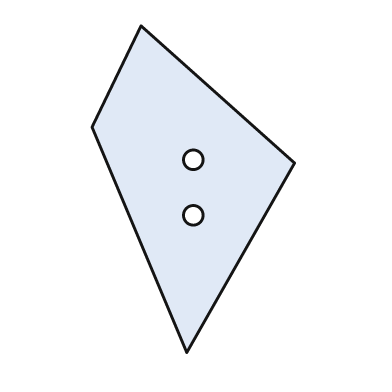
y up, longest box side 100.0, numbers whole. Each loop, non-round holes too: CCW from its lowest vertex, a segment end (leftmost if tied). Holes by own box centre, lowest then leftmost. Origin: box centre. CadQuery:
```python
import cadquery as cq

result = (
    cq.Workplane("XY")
    .moveTo(-2.0, -50.0)
    .lineTo(31.0, 8.0)
    .lineTo(-16.0, 50.0)
    .lineTo(-31.0, 19.0)
    .close()
    .moveTo(0.0, -8.0)
    .circle(3.0)
    .moveTo(0.0, 9.0)
    .circle(3.0)
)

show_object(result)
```